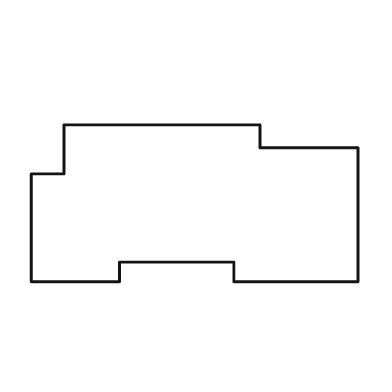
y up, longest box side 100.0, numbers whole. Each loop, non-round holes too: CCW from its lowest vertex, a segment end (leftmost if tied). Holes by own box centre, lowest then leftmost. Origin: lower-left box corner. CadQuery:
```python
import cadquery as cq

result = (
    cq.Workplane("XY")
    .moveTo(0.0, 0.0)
    .lineTo(27.0, 0.0)
    .lineTo(27.0, 6.0)
    .lineTo(62.0, 6.0)
    .lineTo(62.0, 0.0)
    .lineTo(100.0, 0.0)
    .lineTo(100.0, 41.0)
    .lineTo(70.0, 41.0)
    .lineTo(70.0, 48.0)
    .lineTo(10.0, 48.0)
    .lineTo(10.0, 33.0)
    .lineTo(0.0, 33.0)
    .close()
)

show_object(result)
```